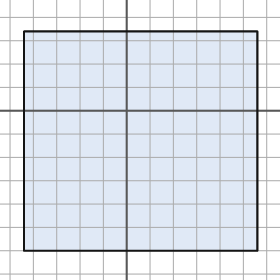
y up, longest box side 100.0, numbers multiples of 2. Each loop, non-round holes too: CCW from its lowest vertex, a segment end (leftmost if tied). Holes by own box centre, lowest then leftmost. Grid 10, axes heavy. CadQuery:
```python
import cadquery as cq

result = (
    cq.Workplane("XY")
    .moveTo(-44.0, -60.0)
    .lineTo(56.0, -60.0)
    .lineTo(56.0, 34.0)
    .lineTo(-44.0, 34.0)
    .close()
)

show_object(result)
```